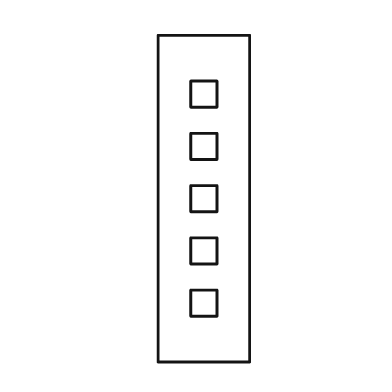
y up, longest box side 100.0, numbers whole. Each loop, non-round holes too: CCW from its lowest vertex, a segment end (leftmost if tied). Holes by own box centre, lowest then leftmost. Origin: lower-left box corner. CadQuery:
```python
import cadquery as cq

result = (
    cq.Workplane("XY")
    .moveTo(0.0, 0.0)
    .lineTo(28.0, 0.0)
    .lineTo(28.0, 100.0)
    .lineTo(0.0, 100.0)
    .close()
    .moveTo(10.0, 14.0)
    .lineTo(18.0, 14.0)
    .lineTo(18.0, 22.0)
    .lineTo(10.0, 22.0)
    .close()
    .moveTo(10.0, 30.0)
    .lineTo(18.0, 30.0)
    .lineTo(18.0, 38.0)
    .lineTo(10.0, 38.0)
    .close()
    .moveTo(10.0, 46.0)
    .lineTo(18.0, 46.0)
    .lineTo(18.0, 54.0)
    .lineTo(10.0, 54.0)
    .close()
    .moveTo(10.0, 62.0)
    .lineTo(18.0, 62.0)
    .lineTo(18.0, 70.0)
    .lineTo(10.0, 70.0)
    .close()
    .moveTo(10.0, 78.0)
    .lineTo(18.0, 78.0)
    .lineTo(18.0, 86.0)
    .lineTo(10.0, 86.0)
    .close()
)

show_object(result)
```